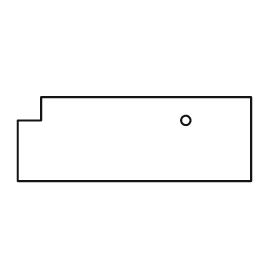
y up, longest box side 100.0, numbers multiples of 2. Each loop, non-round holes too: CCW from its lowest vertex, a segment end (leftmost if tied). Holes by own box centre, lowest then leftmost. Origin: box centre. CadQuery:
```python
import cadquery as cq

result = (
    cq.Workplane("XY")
    .moveTo(-50.0, -18.0)
    .lineTo(50.0, -18.0)
    .lineTo(50.0, 18.0)
    .lineTo(-40.0, 18.0)
    .lineTo(-40.0, 8.0)
    .lineTo(-50.0, 8.0)
    .close()
    .moveTo(22.0, 8.0)
    .circle(2.0)
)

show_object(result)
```